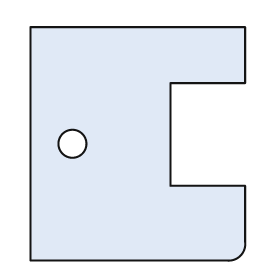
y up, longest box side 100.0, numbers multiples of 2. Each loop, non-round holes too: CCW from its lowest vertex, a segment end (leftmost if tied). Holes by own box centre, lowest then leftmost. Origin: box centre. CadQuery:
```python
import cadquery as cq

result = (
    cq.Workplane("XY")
    .moveTo(-46.0, -50.0)
    .lineTo(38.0, -50.0)
    .threePointArc((44.0, -48.0), (46.0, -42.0))
    .lineTo(46.0, -18.0)
    .lineTo(14.0, -18.0)
    .lineTo(14.0, 26.0)
    .lineTo(46.0, 26.0)
    .lineTo(46.0, 50.0)
    .lineTo(-46.0, 50.0)
    .close()
    .moveTo(-28.0, 0.0)
    .circle(6.0)
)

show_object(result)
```